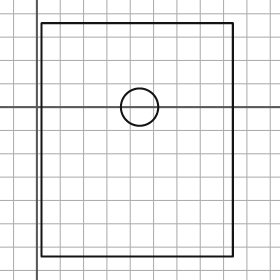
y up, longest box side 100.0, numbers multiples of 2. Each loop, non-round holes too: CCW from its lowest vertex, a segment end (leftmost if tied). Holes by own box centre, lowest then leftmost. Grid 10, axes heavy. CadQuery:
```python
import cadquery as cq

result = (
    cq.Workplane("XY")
    .moveTo(2.0, -64.0)
    .lineTo(84.0, -64.0)
    .lineTo(84.0, 36.0)
    .lineTo(2.0, 36.0)
    .close()
    .moveTo(44.0, 0.0)
    .circle(8.0)
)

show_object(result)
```